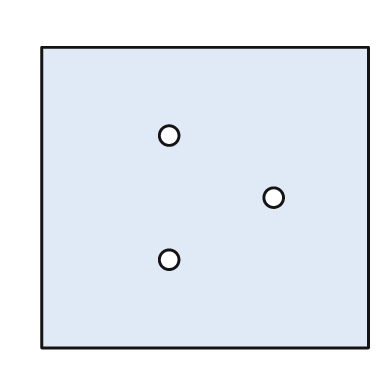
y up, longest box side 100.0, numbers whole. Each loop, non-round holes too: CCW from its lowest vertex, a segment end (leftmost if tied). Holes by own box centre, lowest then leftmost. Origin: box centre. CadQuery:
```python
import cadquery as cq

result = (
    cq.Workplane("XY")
    .moveTo(-50.0, -46.0)
    .lineTo(50.0, -46.0)
    .lineTo(50.0, 46.0)
    .lineTo(-50.0, 46.0)
    .close()
    .moveTo(-11.0, -19.0)
    .circle(3.0)
    .moveTo(21.0, 0.0)
    .circle(3.0)
    .moveTo(-11.0, 19.0)
    .circle(3.0)
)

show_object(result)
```